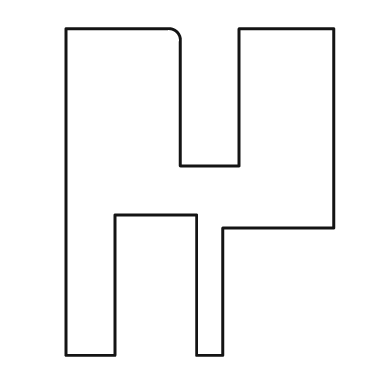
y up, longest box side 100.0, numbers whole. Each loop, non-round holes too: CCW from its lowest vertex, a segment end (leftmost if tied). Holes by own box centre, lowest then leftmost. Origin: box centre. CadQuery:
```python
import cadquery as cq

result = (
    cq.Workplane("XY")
    .moveTo(-41.0, -50.0)
    .lineTo(-26.0, -50.0)
    .lineTo(-26.0, -7.0)
    .lineTo(-1.0, -7.0)
    .lineTo(-1.0, -50.0)
    .lineTo(7.0, -50.0)
    .lineTo(7.0, -11.0)
    .lineTo(41.0, -11.0)
    .lineTo(41.0, 50.0)
    .lineTo(12.0, 50.0)
    .lineTo(12.0, 8.0)
    .lineTo(-6.0, 8.0)
    .lineTo(-6.0, 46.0)
    .threePointArc((-7.0, 49.0), (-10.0, 50.0))
    .lineTo(-41.0, 50.0)
    .close()
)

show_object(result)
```